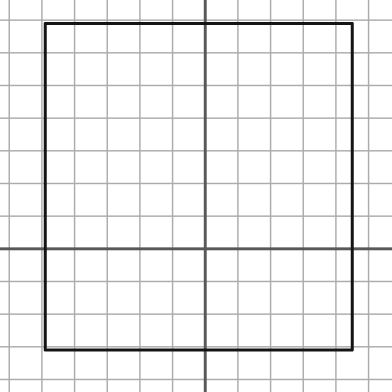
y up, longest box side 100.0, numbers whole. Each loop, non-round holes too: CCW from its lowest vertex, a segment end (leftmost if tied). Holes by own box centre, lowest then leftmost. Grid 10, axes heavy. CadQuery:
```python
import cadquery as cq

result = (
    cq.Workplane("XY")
    .moveTo(-49.0, -31.0)
    .lineTo(45.0, -31.0)
    .lineTo(45.0, 69.0)
    .lineTo(-49.0, 69.0)
    .close()
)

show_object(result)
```